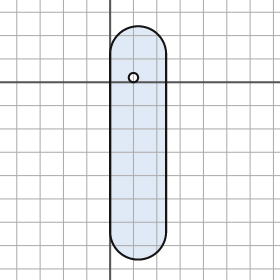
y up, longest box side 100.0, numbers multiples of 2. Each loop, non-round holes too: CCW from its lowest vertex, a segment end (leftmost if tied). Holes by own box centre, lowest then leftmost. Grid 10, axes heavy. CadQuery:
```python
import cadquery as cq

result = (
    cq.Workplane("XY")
    .moveTo(0.0, -64.0)
    .threePointArc((12.0, -76.0), (24.0, -64.0))
    .lineTo(24.0, 12.0)
    .threePointArc((12.0, 24.0), (0.0, 12.0))
    .close()
    .moveTo(10.0, 2.0)
    .circle(2.0)
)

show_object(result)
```